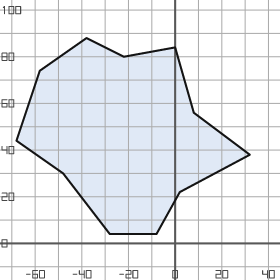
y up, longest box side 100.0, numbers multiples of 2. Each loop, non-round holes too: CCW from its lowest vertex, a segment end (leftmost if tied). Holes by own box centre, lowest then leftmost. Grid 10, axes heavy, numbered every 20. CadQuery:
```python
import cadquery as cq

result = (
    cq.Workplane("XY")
    .moveTo(-28.0, 4.0)
    .lineTo(-8.0, 4.0)
    .lineTo(2.0, 22.0)
    .lineTo(32.0, 38.0)
    .lineTo(8.0, 56.0)
    .lineTo(0.0, 84.0)
    .lineTo(-22.0, 80.0)
    .lineTo(-38.0, 88.0)
    .lineTo(-58.0, 74.0)
    .lineTo(-68.0, 44.0)
    .lineTo(-48.0, 30.0)
    .close()
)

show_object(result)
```